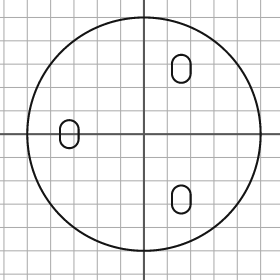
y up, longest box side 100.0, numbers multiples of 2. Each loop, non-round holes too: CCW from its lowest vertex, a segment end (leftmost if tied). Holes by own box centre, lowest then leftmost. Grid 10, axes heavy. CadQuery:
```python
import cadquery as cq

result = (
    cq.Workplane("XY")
    .moveTo(0.0, 0.0)
    .circle(50.0)
    .moveTo(12.0, -30.0)
    .threePointArc((16.0, -34.0), (20.0, -30.0))
    .lineTo(20.0, -26.0)
    .threePointArc((16.0, -22.0), (12.0, -26.0))
    .close()
    .moveTo(-36.0, -2.0)
    .threePointArc((-32.0, -6.0), (-28.0, -2.0))
    .lineTo(-28.0, 2.0)
    .threePointArc((-32.0, 6.0), (-36.0, 2.0))
    .close()
    .moveTo(12.0, 26.0)
    .threePointArc((16.0, 22.0), (20.0, 26.0))
    .lineTo(20.0, 30.0)
    .threePointArc((16.0, 34.0), (12.0, 30.0))
    .close()
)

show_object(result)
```